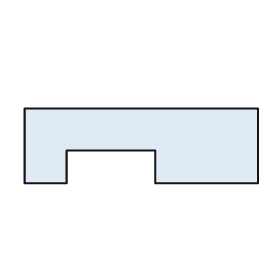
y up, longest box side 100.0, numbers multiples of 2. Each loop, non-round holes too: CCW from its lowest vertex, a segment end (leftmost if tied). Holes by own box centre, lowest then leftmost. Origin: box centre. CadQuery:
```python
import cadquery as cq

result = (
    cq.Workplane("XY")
    .moveTo(-50.0, -16.0)
    .lineTo(-32.0, -16.0)
    .lineTo(-32.0, -2.0)
    .lineTo(6.0, -2.0)
    .lineTo(6.0, -16.0)
    .lineTo(50.0, -16.0)
    .lineTo(50.0, 16.0)
    .lineTo(-50.0, 16.0)
    .close()
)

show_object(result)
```